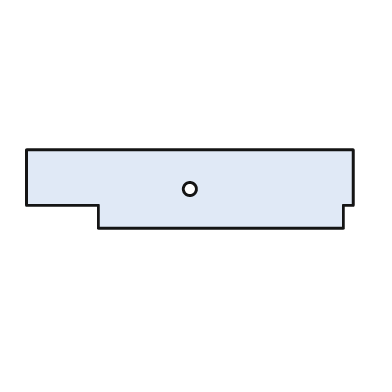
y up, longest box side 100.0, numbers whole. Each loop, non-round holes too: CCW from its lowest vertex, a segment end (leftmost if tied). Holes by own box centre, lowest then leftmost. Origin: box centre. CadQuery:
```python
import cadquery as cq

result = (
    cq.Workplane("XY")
    .moveTo(-28.0, -12.0)
    .lineTo(47.0, -12.0)
    .lineTo(47.0, -5.0)
    .lineTo(50.0, -5.0)
    .lineTo(50.0, 12.0)
    .lineTo(-50.0, 12.0)
    .lineTo(-50.0, -5.0)
    .lineTo(-28.0, -5.0)
    .close()
    .moveTo(0.0, 0.0)
    .circle(2.0)
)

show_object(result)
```